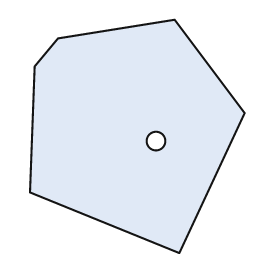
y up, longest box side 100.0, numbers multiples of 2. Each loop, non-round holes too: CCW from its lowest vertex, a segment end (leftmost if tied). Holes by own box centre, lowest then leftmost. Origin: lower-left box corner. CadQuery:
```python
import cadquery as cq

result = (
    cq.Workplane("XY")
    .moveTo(64.0, 0.0)
    .lineTo(92.0, 60.0)
    .lineTo(62.0, 100.0)
    .lineTo(12.0, 92.0)
    .lineTo(2.0, 80.0)
    .lineTo(0.0, 26.0)
    .close()
    .moveTo(54.0, 48.0)
    .circle(4.0)
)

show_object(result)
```